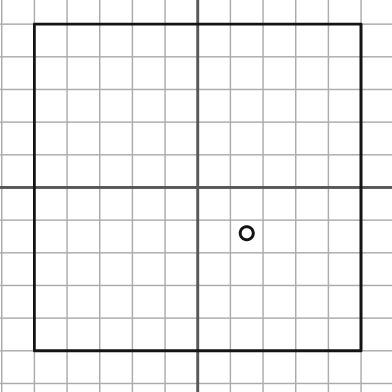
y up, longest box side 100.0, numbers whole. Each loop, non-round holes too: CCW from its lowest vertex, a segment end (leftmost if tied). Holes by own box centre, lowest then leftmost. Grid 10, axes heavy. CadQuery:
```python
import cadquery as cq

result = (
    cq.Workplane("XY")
    .moveTo(-50.0, -50.0)
    .lineTo(50.0, -50.0)
    .lineTo(50.0, 50.0)
    .lineTo(-50.0, 50.0)
    .close()
    .moveTo(15.0, -14.0)
    .circle(2.0)
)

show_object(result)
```